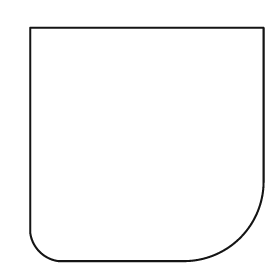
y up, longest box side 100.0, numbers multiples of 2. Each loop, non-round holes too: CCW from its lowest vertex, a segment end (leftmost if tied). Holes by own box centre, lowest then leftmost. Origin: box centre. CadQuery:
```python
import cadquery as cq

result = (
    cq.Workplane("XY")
    .moveTo(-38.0, -50.0)
    .lineTo(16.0, -50.0)
    .threePointArc((40.0, -40.0), (50.0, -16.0))
    .lineTo(50.0, 50.0)
    .lineTo(-50.0, 50.0)
    .lineTo(-50.0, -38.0)
    .threePointArc((-46.0, -46.0), (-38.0, -50.0))
    .close()
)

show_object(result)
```